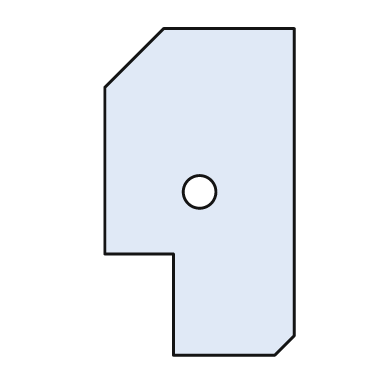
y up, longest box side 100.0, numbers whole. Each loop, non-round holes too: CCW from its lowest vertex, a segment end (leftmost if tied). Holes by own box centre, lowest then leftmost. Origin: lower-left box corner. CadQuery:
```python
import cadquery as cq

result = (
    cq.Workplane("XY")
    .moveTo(21.0, 0.0)
    .lineTo(52.0, 0.0)
    .lineTo(58.0, 6.0)
    .lineTo(58.0, 100.0)
    .lineTo(18.0, 100.0)
    .lineTo(0.0, 82.0)
    .lineTo(0.0, 31.0)
    .lineTo(21.0, 31.0)
    .close()
    .moveTo(29.0, 50.0)
    .circle(5.0)
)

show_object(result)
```